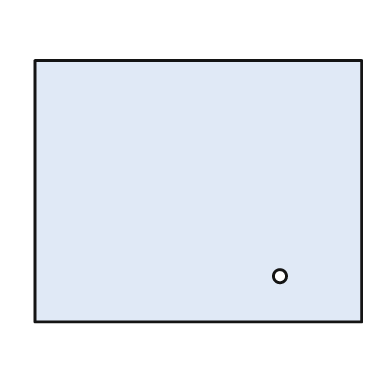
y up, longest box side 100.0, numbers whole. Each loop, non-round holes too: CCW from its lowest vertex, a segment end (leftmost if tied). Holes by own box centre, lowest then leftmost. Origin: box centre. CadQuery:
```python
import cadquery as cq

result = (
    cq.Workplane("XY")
    .moveTo(-50.0, -40.0)
    .lineTo(50.0, -40.0)
    .lineTo(50.0, 40.0)
    .lineTo(-50.0, 40.0)
    .close()
    .moveTo(25.0, -26.0)
    .circle(2.0)
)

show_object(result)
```